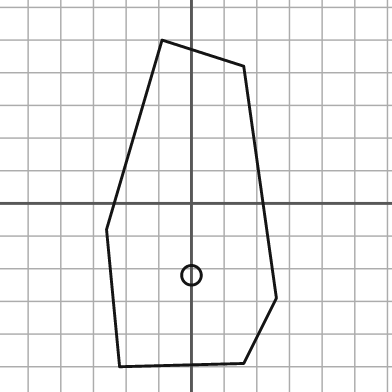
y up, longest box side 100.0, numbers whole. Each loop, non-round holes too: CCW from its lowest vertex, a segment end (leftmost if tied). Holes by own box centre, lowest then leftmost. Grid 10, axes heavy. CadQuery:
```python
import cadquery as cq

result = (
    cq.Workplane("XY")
    .moveTo(-22.0, -50.0)
    .lineTo(16.0, -49.0)
    .lineTo(26.0, -29.0)
    .lineTo(16.0, 42.0)
    .lineTo(-9.0, 50.0)
    .lineTo(-26.0, -8.0)
    .close()
    .moveTo(0.0, -22.0)
    .circle(3.0)
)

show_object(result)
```